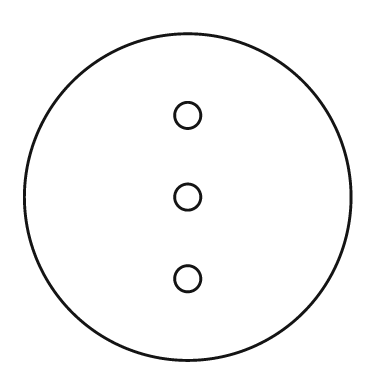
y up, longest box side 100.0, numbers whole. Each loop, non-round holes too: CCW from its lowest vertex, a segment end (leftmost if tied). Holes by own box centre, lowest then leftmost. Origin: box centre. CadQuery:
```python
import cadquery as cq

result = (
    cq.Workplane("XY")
    .moveTo(0.0, 0.0)
    .circle(50.0)
    .moveTo(0.0, -25.0)
    .circle(4.0)
    .moveTo(0.0, 0.0)
    .circle(4.0)
    .moveTo(0.0, 25.0)
    .circle(4.0)
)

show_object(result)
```